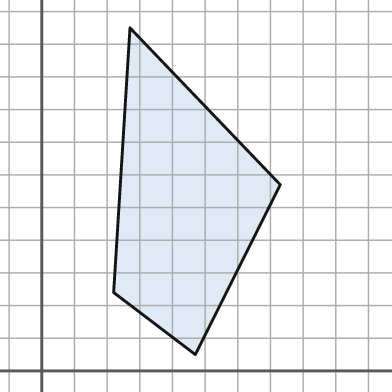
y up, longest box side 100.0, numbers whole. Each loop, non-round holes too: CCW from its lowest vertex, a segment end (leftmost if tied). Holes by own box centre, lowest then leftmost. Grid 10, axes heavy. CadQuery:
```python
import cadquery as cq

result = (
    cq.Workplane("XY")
    .moveTo(47.0, 5.0)
    .lineTo(73.0, 57.0)
    .lineTo(27.0, 105.0)
    .lineTo(22.0, 24.0)
    .close()
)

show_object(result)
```